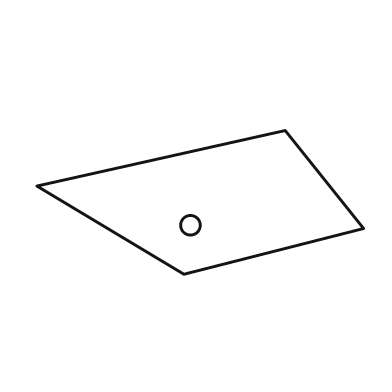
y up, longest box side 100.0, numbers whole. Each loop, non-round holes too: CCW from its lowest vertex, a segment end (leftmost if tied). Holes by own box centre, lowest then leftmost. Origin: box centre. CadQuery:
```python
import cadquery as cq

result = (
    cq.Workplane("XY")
    .moveTo(-5.0, -22.0)
    .lineTo(50.0, -8.0)
    .lineTo(26.0, 22.0)
    .lineTo(-50.0, 5.0)
    .close()
    .moveTo(-3.0, -7.0)
    .circle(3.0)
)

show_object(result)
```